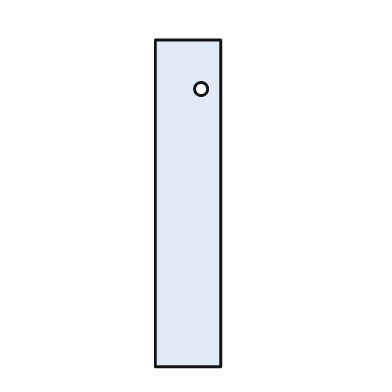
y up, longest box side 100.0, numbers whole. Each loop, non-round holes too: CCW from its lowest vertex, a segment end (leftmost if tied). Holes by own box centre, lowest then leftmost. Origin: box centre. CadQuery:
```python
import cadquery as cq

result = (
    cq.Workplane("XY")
    .moveTo(-10.0, -50.0)
    .lineTo(10.0, -50.0)
    .lineTo(10.0, 50.0)
    .lineTo(-10.0, 50.0)
    .close()
    .moveTo(4.0, 35.0)
    .circle(2.0)
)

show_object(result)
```